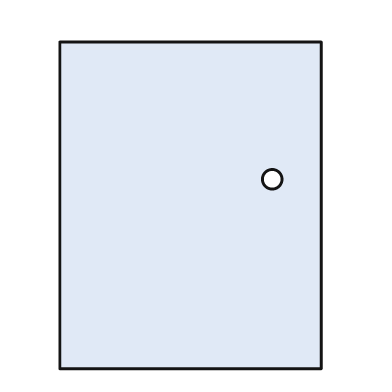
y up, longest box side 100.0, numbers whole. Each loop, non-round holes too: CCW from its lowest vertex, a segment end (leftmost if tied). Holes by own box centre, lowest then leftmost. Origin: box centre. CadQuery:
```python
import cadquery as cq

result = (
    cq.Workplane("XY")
    .moveTo(-40.0, -50.0)
    .lineTo(40.0, -50.0)
    .lineTo(40.0, 50.0)
    .lineTo(-40.0, 50.0)
    .close()
    .moveTo(25.0, 8.0)
    .circle(3.0)
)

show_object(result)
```